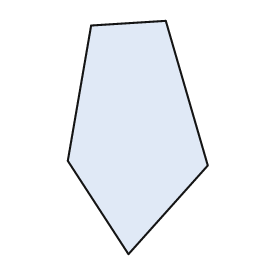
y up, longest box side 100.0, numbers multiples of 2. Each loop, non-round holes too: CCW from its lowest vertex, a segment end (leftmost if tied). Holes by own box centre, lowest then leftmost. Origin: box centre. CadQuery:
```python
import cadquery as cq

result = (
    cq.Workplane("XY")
    .moveTo(-4.0, -50.0)
    .lineTo(30.0, -12.0)
    .lineTo(12.0, 50.0)
    .lineTo(-20.0, 48.0)
    .lineTo(-30.0, -10.0)
    .close()
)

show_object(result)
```